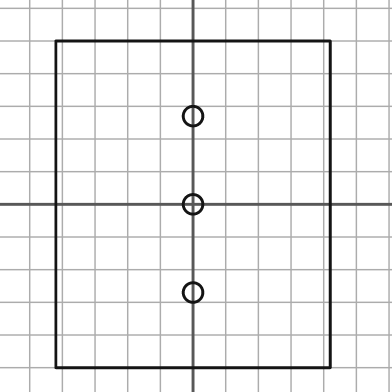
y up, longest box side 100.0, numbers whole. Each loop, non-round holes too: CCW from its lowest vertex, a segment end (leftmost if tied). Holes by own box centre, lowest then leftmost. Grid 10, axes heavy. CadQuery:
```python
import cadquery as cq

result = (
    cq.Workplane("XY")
    .moveTo(-42.0, -50.0)
    .lineTo(42.0, -50.0)
    .lineTo(42.0, 50.0)
    .lineTo(-42.0, 50.0)
    .close()
    .moveTo(0.0, -27.0)
    .circle(3.0)
    .moveTo(0.0, 0.0)
    .circle(3.0)
    .moveTo(0.0, 27.0)
    .circle(3.0)
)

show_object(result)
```